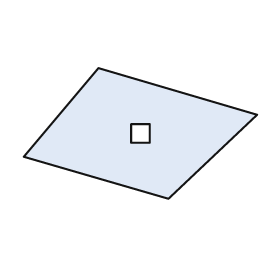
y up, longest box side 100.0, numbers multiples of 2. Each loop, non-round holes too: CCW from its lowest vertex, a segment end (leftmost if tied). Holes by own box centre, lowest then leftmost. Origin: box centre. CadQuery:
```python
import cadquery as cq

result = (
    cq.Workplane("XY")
    .moveTo(12.0, -28.0)
    .lineTo(50.0, 8.0)
    .lineTo(-18.0, 28.0)
    .lineTo(-50.0, -10.0)
    .close()
    .moveTo(-4.0, -4.0)
    .lineTo(4.0, -4.0)
    .lineTo(4.0, 4.0)
    .lineTo(-4.0, 4.0)
    .close()
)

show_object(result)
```